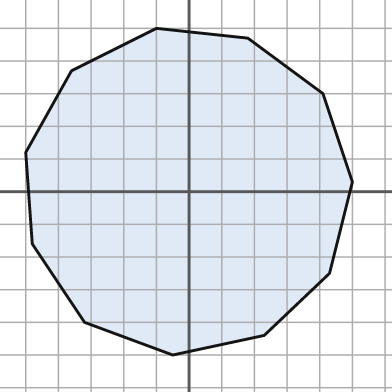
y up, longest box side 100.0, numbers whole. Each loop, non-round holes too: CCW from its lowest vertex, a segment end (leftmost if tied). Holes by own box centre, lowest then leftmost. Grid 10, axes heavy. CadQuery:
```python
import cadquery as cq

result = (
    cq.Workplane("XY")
    .moveTo(-5.0, -50.0)
    .lineTo(23.0, -44.0)
    .lineTo(43.0, -25.0)
    .lineTo(50.0, 3.0)
    .lineTo(41.0, 30.0)
    .lineTo(18.0, 47.0)
    .lineTo(-10.0, 50.0)
    .lineTo(-36.0, 37.0)
    .lineTo(-50.0, 12.0)
    .lineTo(-48.0, -16.0)
    .lineTo(-32.0, -40.0)
    .close()
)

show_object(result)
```